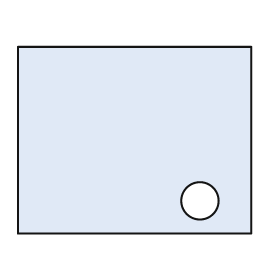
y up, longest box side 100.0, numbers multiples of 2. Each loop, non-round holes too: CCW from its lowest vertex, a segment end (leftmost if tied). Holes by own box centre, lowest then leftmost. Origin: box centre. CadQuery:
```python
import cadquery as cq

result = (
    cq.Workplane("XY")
    .moveTo(-50.0, -40.0)
    .lineTo(50.0, -40.0)
    .lineTo(50.0, 40.0)
    .lineTo(-50.0, 40.0)
    .close()
    .moveTo(28.0, -26.0)
    .circle(8.0)
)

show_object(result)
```